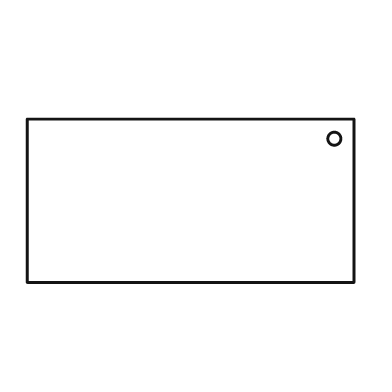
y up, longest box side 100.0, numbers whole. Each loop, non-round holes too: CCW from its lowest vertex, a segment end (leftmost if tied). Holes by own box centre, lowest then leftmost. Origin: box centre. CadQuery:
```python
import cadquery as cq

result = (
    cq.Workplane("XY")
    .moveTo(-50.0, -25.0)
    .lineTo(50.0, -25.0)
    .lineTo(50.0, 25.0)
    .lineTo(-50.0, 25.0)
    .close()
    .moveTo(44.0, 19.0)
    .circle(2.0)
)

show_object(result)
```